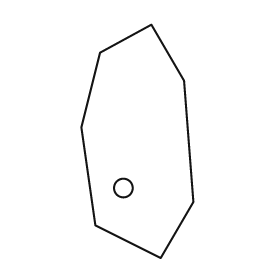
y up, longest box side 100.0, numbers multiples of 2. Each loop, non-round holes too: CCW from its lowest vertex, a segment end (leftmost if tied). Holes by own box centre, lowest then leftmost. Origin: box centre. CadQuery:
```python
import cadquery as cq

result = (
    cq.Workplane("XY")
    .moveTo(10.0, -50.0)
    .lineTo(24.0, -26.0)
    .lineTo(20.0, 26.0)
    .lineTo(6.0, 50.0)
    .lineTo(-16.0, 38.0)
    .lineTo(-24.0, 6.0)
    .lineTo(-18.0, -36.0)
    .close()
    .moveTo(-6.0, -20.0)
    .circle(4.0)
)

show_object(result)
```